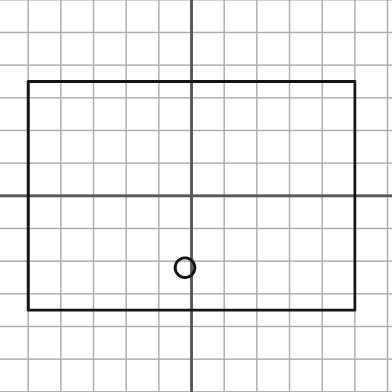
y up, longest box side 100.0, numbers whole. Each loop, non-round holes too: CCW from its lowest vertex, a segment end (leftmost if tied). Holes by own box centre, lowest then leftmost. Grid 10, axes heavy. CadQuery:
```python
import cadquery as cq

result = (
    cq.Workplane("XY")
    .moveTo(-50.0, -35.0)
    .lineTo(50.0, -35.0)
    .lineTo(50.0, 35.0)
    .lineTo(-50.0, 35.0)
    .close()
    .moveTo(-2.0, -22.0)
    .circle(3.0)
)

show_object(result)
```